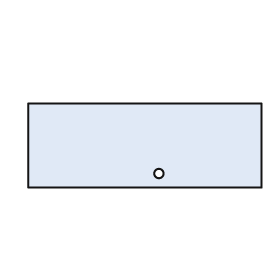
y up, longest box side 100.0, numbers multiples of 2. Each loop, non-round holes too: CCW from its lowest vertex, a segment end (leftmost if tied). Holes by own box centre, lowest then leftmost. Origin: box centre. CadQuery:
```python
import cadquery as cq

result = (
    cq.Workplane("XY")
    .moveTo(-50.0, -18.0)
    .lineTo(50.0, -18.0)
    .lineTo(50.0, 18.0)
    .lineTo(-50.0, 18.0)
    .close()
    .moveTo(6.0, -12.0)
    .circle(2.0)
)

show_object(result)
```